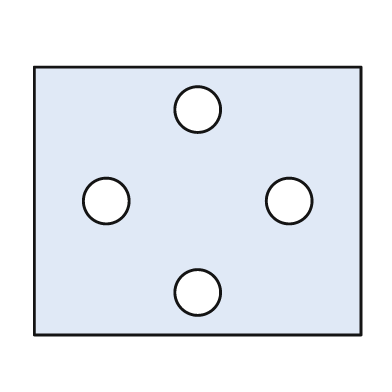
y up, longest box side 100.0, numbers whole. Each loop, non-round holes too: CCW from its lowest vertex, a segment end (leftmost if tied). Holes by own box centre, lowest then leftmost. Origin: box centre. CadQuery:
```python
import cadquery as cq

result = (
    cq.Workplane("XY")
    .moveTo(-50.0, -41.0)
    .lineTo(50.0, -41.0)
    .lineTo(50.0, 41.0)
    .lineTo(-50.0, 41.0)
    .close()
    .moveTo(0.0, -28.0)
    .circle(7.0)
    .moveTo(-28.0, 0.0)
    .circle(7.0)
    .moveTo(28.0, 0.0)
    .circle(7.0)
    .moveTo(0.0, 28.0)
    .circle(7.0)
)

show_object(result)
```